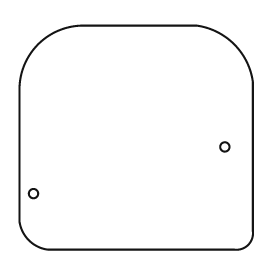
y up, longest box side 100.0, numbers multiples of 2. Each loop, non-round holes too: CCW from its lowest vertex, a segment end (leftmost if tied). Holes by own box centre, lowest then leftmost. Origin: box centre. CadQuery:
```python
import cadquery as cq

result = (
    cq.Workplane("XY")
    .moveTo(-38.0, -48.0)
    .lineTo(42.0, -48.0)
    .threePointArc((48.0, -46.0), (50.0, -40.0))
    .lineTo(50.0, 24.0)
    .threePointArc((42.0, 40.0), (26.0, 48.0))
    .lineTo(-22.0, 48.0)
    .threePointArc((-42.0, 40.0), (-50.0, 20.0))
    .lineTo(-50.0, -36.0)
    .threePointArc((-46.0, -44.0), (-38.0, -48.0))
    .close()
    .moveTo(-44.0, -24.0)
    .circle(2.0)
    .moveTo(38.0, -4.0)
    .circle(2.0)
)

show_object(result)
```